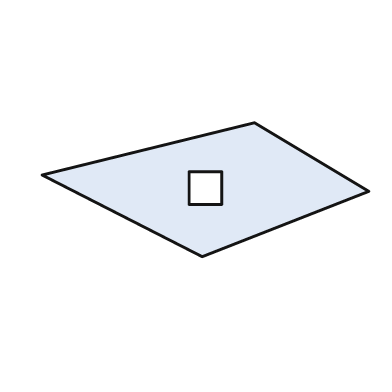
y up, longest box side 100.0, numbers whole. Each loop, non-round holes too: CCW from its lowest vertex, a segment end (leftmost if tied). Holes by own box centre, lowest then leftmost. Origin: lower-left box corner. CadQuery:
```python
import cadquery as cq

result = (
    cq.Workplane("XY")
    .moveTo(49.0, 0.0)
    .lineTo(100.0, 20.0)
    .lineTo(65.0, 41.0)
    .lineTo(0.0, 25.0)
    .close()
    .moveTo(45.0, 16.0)
    .lineTo(55.0, 16.0)
    .lineTo(55.0, 26.0)
    .lineTo(45.0, 26.0)
    .close()
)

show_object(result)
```